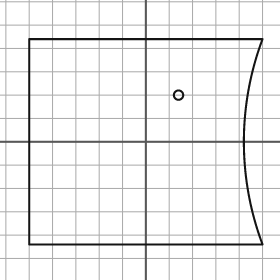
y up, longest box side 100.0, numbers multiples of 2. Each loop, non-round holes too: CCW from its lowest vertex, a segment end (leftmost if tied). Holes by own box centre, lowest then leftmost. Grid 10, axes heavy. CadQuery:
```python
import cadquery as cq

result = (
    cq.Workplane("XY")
    .moveTo(-50.0, -44.0)
    .lineTo(50.0, -44.0)
    .threePointArc((42.0, 0.0), (50.0, 44.0))
    .lineTo(-50.0, 44.0)
    .close()
    .moveTo(14.0, 20.0)
    .circle(2.0)
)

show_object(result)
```